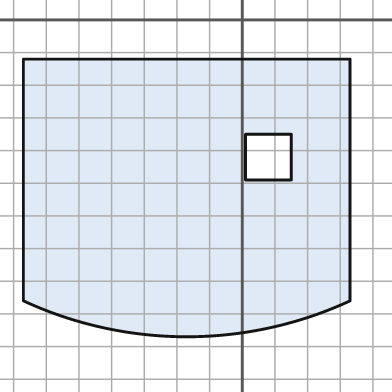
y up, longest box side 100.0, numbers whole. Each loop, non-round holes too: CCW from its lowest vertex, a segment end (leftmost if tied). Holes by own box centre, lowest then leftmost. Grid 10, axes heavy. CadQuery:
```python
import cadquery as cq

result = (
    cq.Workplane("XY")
    .moveTo(-67.0, -86.0)
    .threePointArc((-17.0, -97.0), (33.0, -86.0))
    .lineTo(33.0, -12.0)
    .lineTo(-67.0, -12.0)
    .close()
    .moveTo(1.0, -49.0)
    .lineTo(15.0, -49.0)
    .lineTo(15.0, -35.0)
    .lineTo(1.0, -35.0)
    .close()
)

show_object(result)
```